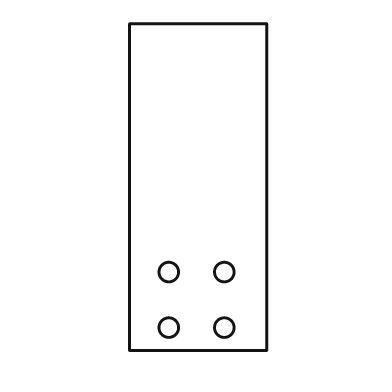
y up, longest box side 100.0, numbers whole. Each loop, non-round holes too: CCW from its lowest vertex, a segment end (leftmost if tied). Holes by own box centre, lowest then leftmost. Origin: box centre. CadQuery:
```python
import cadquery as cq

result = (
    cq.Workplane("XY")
    .moveTo(-21.0, -50.0)
    .lineTo(21.0, -50.0)
    .lineTo(21.0, 50.0)
    .lineTo(-21.0, 50.0)
    .close()
    .moveTo(-9.0, -43.0)
    .circle(3.0)
    .moveTo(8.0, -43.0)
    .circle(3.0)
    .moveTo(-9.0, -26.0)
    .circle(3.0)
    .moveTo(8.0, -26.0)
    .circle(3.0)
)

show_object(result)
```